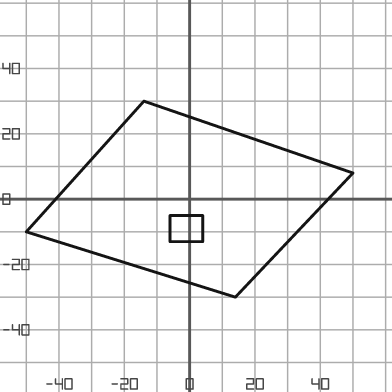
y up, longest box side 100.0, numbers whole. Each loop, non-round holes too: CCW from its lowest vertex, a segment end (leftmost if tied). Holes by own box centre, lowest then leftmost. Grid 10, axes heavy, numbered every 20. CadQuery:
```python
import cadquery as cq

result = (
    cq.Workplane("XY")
    .moveTo(14.0, -30.0)
    .lineTo(50.0, 8.0)
    .lineTo(-14.0, 30.0)
    .lineTo(-50.0, -10.0)
    .close()
    .moveTo(-6.0, -13.0)
    .lineTo(4.0, -13.0)
    .lineTo(4.0, -5.0)
    .lineTo(-6.0, -5.0)
    .close()
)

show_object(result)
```